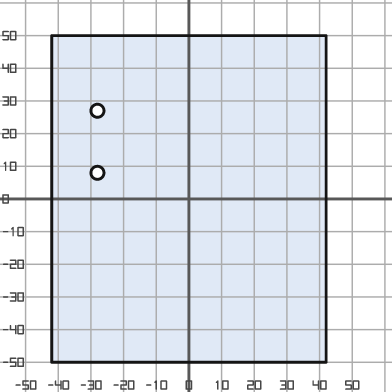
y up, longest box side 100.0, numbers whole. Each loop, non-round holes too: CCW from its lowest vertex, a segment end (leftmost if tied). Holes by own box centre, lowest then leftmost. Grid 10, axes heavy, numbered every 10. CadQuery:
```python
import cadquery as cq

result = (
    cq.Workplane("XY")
    .moveTo(-42.0, -50.0)
    .lineTo(42.0, -50.0)
    .lineTo(42.0, 50.0)
    .lineTo(-42.0, 50.0)
    .close()
    .moveTo(-28.0, 8.0)
    .circle(2.0)
    .moveTo(-28.0, 27.0)
    .circle(2.0)
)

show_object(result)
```